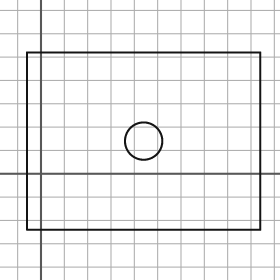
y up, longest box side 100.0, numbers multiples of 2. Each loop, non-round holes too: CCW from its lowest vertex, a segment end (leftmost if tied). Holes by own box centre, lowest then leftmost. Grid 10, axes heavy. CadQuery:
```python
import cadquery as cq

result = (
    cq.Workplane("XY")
    .moveTo(-6.0, -24.0)
    .lineTo(94.0, -24.0)
    .lineTo(94.0, 52.0)
    .lineTo(-6.0, 52.0)
    .close()
    .moveTo(44.0, 14.0)
    .circle(8.0)
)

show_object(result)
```